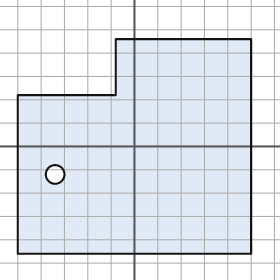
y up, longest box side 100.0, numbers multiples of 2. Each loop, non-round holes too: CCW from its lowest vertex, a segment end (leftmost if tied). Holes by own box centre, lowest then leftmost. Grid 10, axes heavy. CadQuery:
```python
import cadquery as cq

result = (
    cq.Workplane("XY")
    .moveTo(-50.0, -46.0)
    .lineTo(50.0, -46.0)
    .lineTo(50.0, 46.0)
    .lineTo(-8.0, 46.0)
    .lineTo(-8.0, 22.0)
    .lineTo(-50.0, 22.0)
    .close()
    .moveTo(-34.0, -12.0)
    .circle(4.0)
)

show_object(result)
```